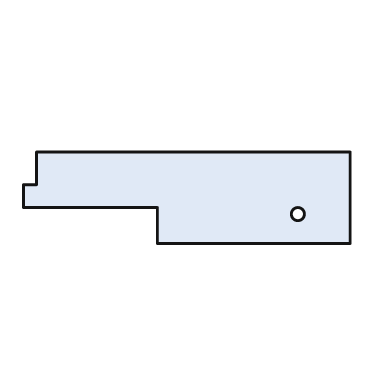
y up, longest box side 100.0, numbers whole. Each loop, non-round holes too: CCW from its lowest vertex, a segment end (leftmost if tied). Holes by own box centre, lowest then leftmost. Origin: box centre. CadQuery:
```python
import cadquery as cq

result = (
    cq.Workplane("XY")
    .moveTo(-9.0, -14.0)
    .lineTo(50.0, -14.0)
    .lineTo(50.0, 14.0)
    .lineTo(-46.0, 14.0)
    .lineTo(-46.0, 4.0)
    .lineTo(-50.0, 4.0)
    .lineTo(-50.0, -3.0)
    .lineTo(-9.0, -3.0)
    .close()
    .moveTo(34.0, -5.0)
    .circle(2.0)
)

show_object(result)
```